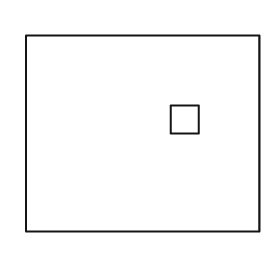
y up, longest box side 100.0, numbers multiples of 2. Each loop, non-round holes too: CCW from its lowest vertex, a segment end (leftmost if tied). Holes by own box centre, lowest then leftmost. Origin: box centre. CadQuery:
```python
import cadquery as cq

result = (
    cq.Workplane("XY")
    .moveTo(-50.0, -42.0)
    .lineTo(50.0, -42.0)
    .lineTo(50.0, 42.0)
    .lineTo(-50.0, 42.0)
    .close()
    .moveTo(12.0, 0.0)
    .lineTo(24.0, 0.0)
    .lineTo(24.0, 12.0)
    .lineTo(12.0, 12.0)
    .close()
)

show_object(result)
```